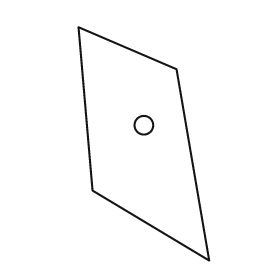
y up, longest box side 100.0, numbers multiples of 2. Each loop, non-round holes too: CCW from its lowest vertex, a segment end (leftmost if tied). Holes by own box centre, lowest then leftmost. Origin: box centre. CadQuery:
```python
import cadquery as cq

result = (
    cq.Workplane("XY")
    .moveTo(28.0, -50.0)
    .lineTo(14.0, 32.0)
    .lineTo(-28.0, 50.0)
    .lineTo(-22.0, -20.0)
    .close()
    .moveTo(0.0, 8.0)
    .circle(4.0)
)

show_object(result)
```